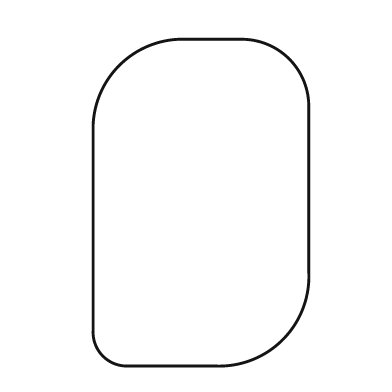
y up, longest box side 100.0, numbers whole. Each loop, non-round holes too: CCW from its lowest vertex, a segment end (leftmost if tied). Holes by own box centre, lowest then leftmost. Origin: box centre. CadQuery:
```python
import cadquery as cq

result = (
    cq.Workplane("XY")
    .moveTo(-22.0, -50.0)
    .lineTo(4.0, -50.0)
    .threePointArc((25.0, -42.0), (33.0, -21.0))
    .lineTo(33.0, 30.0)
    .threePointArc((27.0, 44.0), (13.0, 50.0))
    .lineTo(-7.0, 50.0)
    .threePointArc((-25.0, 42.0), (-33.0, 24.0))
    .lineTo(-33.0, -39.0)
    .threePointArc((-30.0, -47.0), (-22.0, -50.0))
    .close()
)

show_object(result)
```